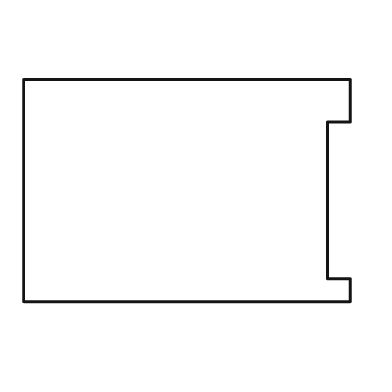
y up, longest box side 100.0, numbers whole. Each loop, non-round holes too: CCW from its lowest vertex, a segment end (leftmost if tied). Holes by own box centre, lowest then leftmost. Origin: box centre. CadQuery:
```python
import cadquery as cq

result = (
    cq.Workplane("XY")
    .moveTo(-50.0, -34.0)
    .lineTo(50.0, -34.0)
    .lineTo(50.0, -27.0)
    .lineTo(43.0, -27.0)
    .lineTo(43.0, 21.0)
    .lineTo(50.0, 21.0)
    .lineTo(50.0, 34.0)
    .lineTo(-50.0, 34.0)
    .close()
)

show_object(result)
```